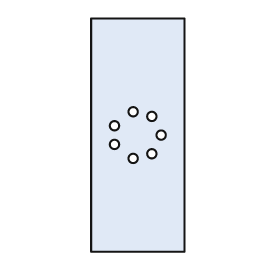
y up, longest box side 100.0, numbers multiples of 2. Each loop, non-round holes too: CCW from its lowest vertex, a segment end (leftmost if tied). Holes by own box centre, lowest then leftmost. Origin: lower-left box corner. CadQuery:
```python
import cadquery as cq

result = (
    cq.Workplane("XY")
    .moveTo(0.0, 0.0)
    .lineTo(40.0, 0.0)
    .lineTo(40.0, 100.0)
    .lineTo(0.0, 100.0)
    .close()
    .moveTo(18.0, 40.0)
    .circle(2.0)
    .moveTo(26.0, 42.0)
    .circle(2.0)
    .moveTo(10.0, 46.0)
    .circle(2.0)
    .moveTo(30.0, 50.0)
    .circle(2.0)
    .moveTo(10.0, 54.0)
    .circle(2.0)
    .moveTo(26.0, 58.0)
    .circle(2.0)
    .moveTo(18.0, 60.0)
    .circle(2.0)
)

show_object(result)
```